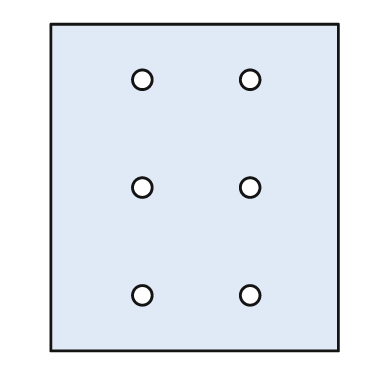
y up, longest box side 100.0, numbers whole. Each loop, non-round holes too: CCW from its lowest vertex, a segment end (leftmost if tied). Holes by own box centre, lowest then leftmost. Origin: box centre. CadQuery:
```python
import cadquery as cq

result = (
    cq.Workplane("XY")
    .moveTo(-44.0, -50.0)
    .lineTo(44.0, -50.0)
    .lineTo(44.0, 50.0)
    .lineTo(-44.0, 50.0)
    .close()
    .moveTo(-16.0, -33.0)
    .circle(3.0)
    .moveTo(17.0, -33.0)
    .circle(3.0)
    .moveTo(-16.0, 0.0)
    .circle(3.0)
    .moveTo(17.0, 0.0)
    .circle(3.0)
    .moveTo(-16.0, 33.0)
    .circle(3.0)
    .moveTo(17.0, 33.0)
    .circle(3.0)
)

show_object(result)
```